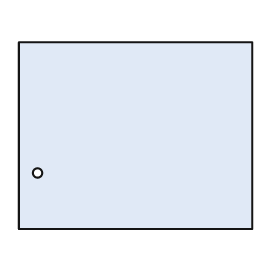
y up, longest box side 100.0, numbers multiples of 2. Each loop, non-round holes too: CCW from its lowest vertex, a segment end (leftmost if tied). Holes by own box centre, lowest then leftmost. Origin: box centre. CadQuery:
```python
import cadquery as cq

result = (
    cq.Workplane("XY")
    .moveTo(-50.0, -40.0)
    .lineTo(50.0, -40.0)
    .lineTo(50.0, 40.0)
    .lineTo(-50.0, 40.0)
    .close()
    .moveTo(-42.0, -16.0)
    .circle(2.0)
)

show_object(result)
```